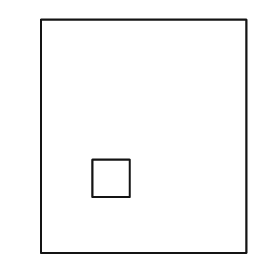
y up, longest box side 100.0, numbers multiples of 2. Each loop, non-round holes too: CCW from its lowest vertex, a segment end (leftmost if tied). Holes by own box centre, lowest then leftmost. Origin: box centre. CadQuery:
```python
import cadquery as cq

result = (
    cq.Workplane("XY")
    .moveTo(-44.0, -50.0)
    .lineTo(44.0, -50.0)
    .lineTo(44.0, 50.0)
    .lineTo(-44.0, 50.0)
    .close()
    .moveTo(-22.0, -26.0)
    .lineTo(-6.0, -26.0)
    .lineTo(-6.0, -10.0)
    .lineTo(-22.0, -10.0)
    .close()
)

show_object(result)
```